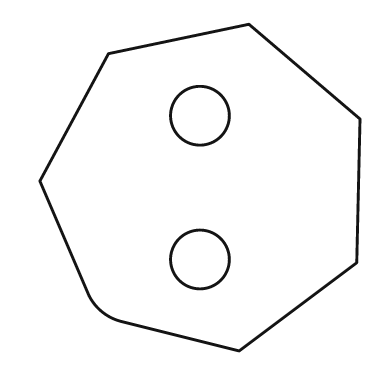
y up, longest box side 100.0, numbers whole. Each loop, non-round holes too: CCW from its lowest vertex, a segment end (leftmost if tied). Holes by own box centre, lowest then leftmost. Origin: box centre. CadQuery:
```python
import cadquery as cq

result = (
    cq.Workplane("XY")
    .moveTo(12.0, -50.0)
    .lineTo(48.0, -23.0)
    .lineTo(49.0, 21.0)
    .lineTo(15.0, 50.0)
    .lineTo(-28.0, 41.0)
    .lineTo(-49.0, 2.0)
    .lineTo(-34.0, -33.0)
    .threePointArc((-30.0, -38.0), (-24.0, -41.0))
    .close()
    .moveTo(0.0, -22.0)
    .circle(9.0)
    .moveTo(0.0, 22.0)
    .circle(9.0)
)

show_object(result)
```